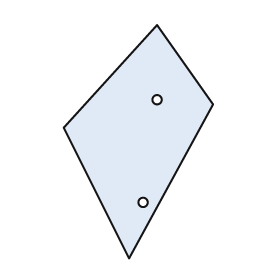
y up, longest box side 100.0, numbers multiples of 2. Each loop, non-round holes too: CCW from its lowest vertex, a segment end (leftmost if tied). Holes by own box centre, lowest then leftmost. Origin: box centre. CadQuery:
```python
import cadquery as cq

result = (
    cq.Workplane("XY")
    .moveTo(-4.0, -50.0)
    .lineTo(32.0, 16.0)
    .lineTo(8.0, 50.0)
    .lineTo(-32.0, 6.0)
    .close()
    .moveTo(2.0, -26.0)
    .circle(2.0)
    .moveTo(8.0, 18.0)
    .circle(2.0)
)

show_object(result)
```